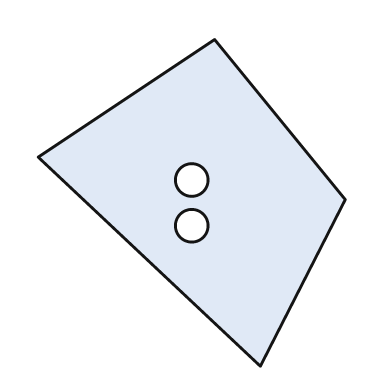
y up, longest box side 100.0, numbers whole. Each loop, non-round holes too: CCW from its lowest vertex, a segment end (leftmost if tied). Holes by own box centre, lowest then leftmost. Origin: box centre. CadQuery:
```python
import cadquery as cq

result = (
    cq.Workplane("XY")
    .moveTo(21.0, -50.0)
    .lineTo(47.0, 1.0)
    .lineTo(7.0, 50.0)
    .lineTo(-47.0, 14.0)
    .close()
    .moveTo(0.0, -7.0)
    .circle(5.0)
    .moveTo(0.0, 7.0)
    .circle(5.0)
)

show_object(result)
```